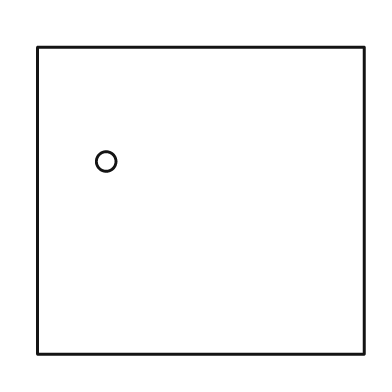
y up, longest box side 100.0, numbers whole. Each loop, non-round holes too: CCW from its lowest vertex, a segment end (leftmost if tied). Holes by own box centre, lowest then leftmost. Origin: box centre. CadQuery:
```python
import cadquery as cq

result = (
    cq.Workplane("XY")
    .moveTo(-50.0, -47.0)
    .lineTo(50.0, -47.0)
    .lineTo(50.0, 47.0)
    .lineTo(-50.0, 47.0)
    .close()
    .moveTo(-29.0, 12.0)
    .circle(3.0)
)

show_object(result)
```